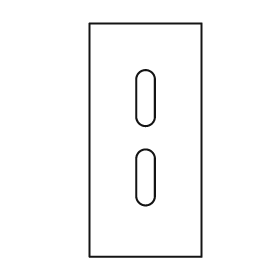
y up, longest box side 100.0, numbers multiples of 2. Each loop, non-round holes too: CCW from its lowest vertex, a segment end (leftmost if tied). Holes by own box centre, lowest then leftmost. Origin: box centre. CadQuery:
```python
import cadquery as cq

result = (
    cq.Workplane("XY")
    .moveTo(-24.0, -50.0)
    .lineTo(24.0, -50.0)
    .lineTo(24.0, 50.0)
    .lineTo(-24.0, 50.0)
    .close()
    .moveTo(-4.0, -24.0)
    .threePointArc((0.0, -28.0), (4.0, -24.0))
    .lineTo(4.0, -8.0)
    .threePointArc((0.0, -4.0), (-4.0, -8.0))
    .close()
    .moveTo(-4.0, 10.0)
    .threePointArc((0.0, 6.0), (4.0, 10.0))
    .lineTo(4.0, 26.0)
    .threePointArc((0.0, 30.0), (-4.0, 26.0))
    .close()
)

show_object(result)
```